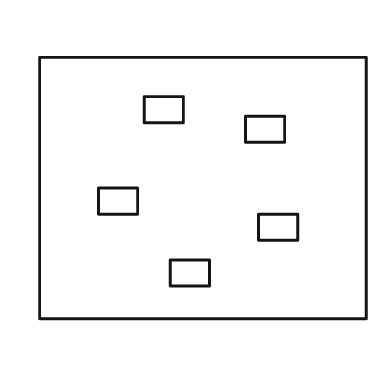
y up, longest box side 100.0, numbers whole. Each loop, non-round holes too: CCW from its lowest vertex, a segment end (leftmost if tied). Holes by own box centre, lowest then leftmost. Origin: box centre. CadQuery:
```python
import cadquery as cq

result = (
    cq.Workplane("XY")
    .moveTo(-50.0, -40.0)
    .lineTo(50.0, -40.0)
    .lineTo(50.0, 40.0)
    .lineTo(-50.0, 40.0)
    .close()
    .moveTo(-10.0, -30.0)
    .lineTo(2.0, -30.0)
    .lineTo(2.0, -22.0)
    .lineTo(-10.0, -22.0)
    .close()
    .moveTo(17.0, -16.0)
    .lineTo(29.0, -16.0)
    .lineTo(29.0, -8.0)
    .lineTo(17.0, -8.0)
    .close()
    .moveTo(-32.0, -8.0)
    .lineTo(-20.0, -8.0)
    .lineTo(-20.0, 0.0)
    .lineTo(-32.0, 0.0)
    .close()
    .moveTo(13.0, 14.0)
    .lineTo(25.0, 14.0)
    .lineTo(25.0, 22.0)
    .lineTo(13.0, 22.0)
    .close()
    .moveTo(-18.0, 20.0)
    .lineTo(-6.0, 20.0)
    .lineTo(-6.0, 28.0)
    .lineTo(-18.0, 28.0)
    .close()
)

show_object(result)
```